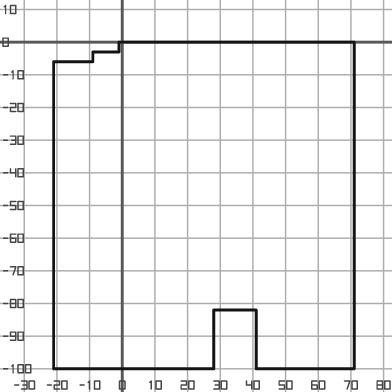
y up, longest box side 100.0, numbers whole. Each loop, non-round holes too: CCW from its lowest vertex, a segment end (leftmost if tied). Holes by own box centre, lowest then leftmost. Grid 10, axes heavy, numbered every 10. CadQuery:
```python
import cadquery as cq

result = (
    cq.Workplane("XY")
    .moveTo(-21.0, -100.0)
    .lineTo(28.0, -100.0)
    .lineTo(28.0, -82.0)
    .lineTo(41.0, -82.0)
    .lineTo(41.0, -100.0)
    .lineTo(71.0, -100.0)
    .lineTo(71.0, 0.0)
    .lineTo(-1.0, 0.0)
    .lineTo(-1.0, -3.0)
    .lineTo(-9.0, -3.0)
    .lineTo(-9.0, -6.0)
    .lineTo(-21.0, -6.0)
    .close()
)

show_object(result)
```